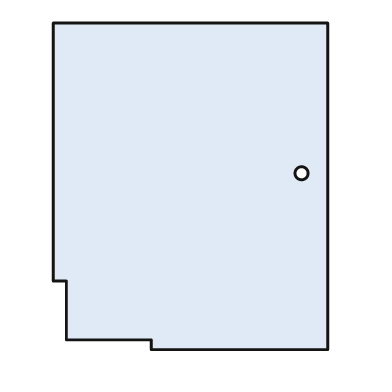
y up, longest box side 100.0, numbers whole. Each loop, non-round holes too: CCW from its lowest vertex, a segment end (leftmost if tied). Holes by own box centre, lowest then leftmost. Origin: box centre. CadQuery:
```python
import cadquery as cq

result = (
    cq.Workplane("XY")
    .moveTo(-12.0, -50.0)
    .lineTo(42.0, -50.0)
    .lineTo(42.0, 50.0)
    .lineTo(-42.0, 50.0)
    .lineTo(-42.0, -29.0)
    .lineTo(-38.0, -29.0)
    .lineTo(-38.0, -47.0)
    .lineTo(-12.0, -47.0)
    .close()
    .moveTo(34.0, 4.0)
    .circle(2.0)
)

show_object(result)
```